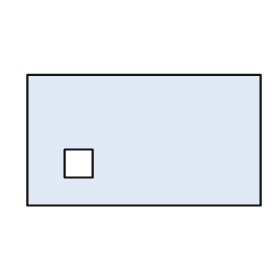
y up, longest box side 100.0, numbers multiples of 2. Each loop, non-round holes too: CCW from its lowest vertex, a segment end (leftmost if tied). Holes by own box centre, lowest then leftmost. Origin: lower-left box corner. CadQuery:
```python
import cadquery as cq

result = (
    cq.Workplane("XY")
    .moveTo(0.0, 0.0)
    .lineTo(100.0, 0.0)
    .lineTo(100.0, 56.0)
    .lineTo(0.0, 56.0)
    .close()
    .moveTo(16.0, 12.0)
    .lineTo(28.0, 12.0)
    .lineTo(28.0, 24.0)
    .lineTo(16.0, 24.0)
    .close()
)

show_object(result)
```